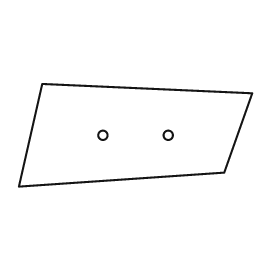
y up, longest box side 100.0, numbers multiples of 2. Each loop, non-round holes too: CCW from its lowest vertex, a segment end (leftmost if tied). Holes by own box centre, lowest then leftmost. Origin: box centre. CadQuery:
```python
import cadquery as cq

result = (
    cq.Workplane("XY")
    .moveTo(-50.0, -22.0)
    .lineTo(38.0, -16.0)
    .lineTo(50.0, 18.0)
    .lineTo(-40.0, 22.0)
    .close()
    .moveTo(-14.0, 0.0)
    .circle(2.0)
    .moveTo(14.0, 0.0)
    .circle(2.0)
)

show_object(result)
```